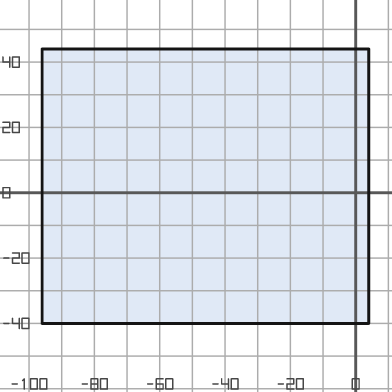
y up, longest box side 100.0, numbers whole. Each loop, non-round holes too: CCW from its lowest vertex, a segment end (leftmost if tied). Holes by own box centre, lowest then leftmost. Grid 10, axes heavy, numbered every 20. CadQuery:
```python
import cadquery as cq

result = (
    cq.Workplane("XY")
    .moveTo(-96.0, -40.0)
    .lineTo(4.0, -40.0)
    .lineTo(4.0, 44.0)
    .lineTo(-96.0, 44.0)
    .close()
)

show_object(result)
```